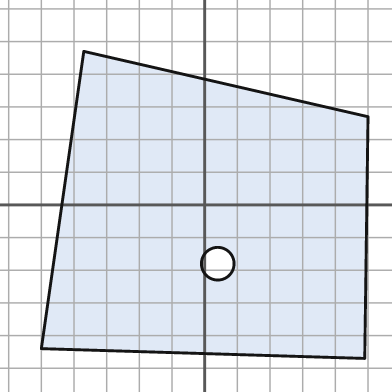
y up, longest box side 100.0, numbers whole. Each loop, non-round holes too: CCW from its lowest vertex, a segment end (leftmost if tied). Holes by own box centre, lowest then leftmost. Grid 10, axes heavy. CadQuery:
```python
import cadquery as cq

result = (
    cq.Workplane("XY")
    .moveTo(49.0, -47.0)
    .lineTo(50.0, 27.0)
    .lineTo(-37.0, 47.0)
    .lineTo(-50.0, -44.0)
    .close()
    .moveTo(4.0, -18.0)
    .circle(5.0)
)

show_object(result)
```